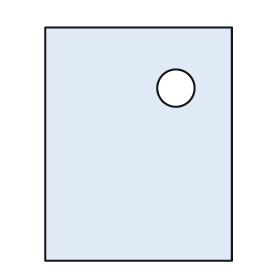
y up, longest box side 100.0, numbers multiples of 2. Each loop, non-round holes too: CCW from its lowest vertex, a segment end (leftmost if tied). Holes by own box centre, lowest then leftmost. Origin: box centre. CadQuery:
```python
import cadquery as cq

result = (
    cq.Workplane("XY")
    .moveTo(-40.0, -50.0)
    .lineTo(40.0, -50.0)
    .lineTo(40.0, 50.0)
    .lineTo(-40.0, 50.0)
    .close()
    .moveTo(16.0, 24.0)
    .circle(8.0)
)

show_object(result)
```